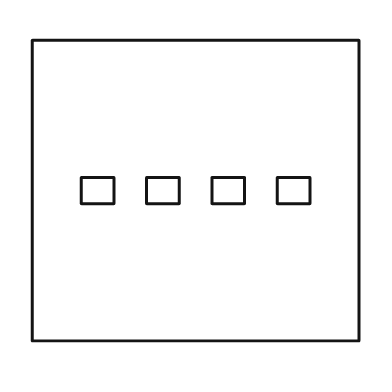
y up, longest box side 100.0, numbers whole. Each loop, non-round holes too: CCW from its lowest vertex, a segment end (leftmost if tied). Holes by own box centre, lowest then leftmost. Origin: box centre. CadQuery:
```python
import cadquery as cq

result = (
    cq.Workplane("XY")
    .moveTo(-50.0, -46.0)
    .lineTo(50.0, -46.0)
    .lineTo(50.0, 46.0)
    .lineTo(-50.0, 46.0)
    .close()
    .moveTo(-35.0, -4.0)
    .lineTo(-25.0, -4.0)
    .lineTo(-25.0, 4.0)
    .lineTo(-35.0, 4.0)
    .close()
    .moveTo(-15.0, -4.0)
    .lineTo(-5.0, -4.0)
    .lineTo(-5.0, 4.0)
    .lineTo(-15.0, 4.0)
    .close()
    .moveTo(5.0, -4.0)
    .lineTo(15.0, -4.0)
    .lineTo(15.0, 4.0)
    .lineTo(5.0, 4.0)
    .close()
    .moveTo(25.0, -4.0)
    .lineTo(35.0, -4.0)
    .lineTo(35.0, 4.0)
    .lineTo(25.0, 4.0)
    .close()
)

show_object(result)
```